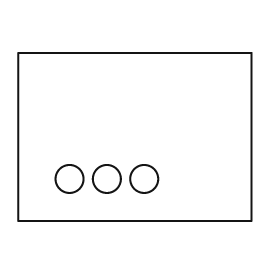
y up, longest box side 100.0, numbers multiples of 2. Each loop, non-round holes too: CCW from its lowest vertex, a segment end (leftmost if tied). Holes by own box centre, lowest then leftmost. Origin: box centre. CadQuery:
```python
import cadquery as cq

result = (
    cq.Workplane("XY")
    .moveTo(-50.0, -36.0)
    .lineTo(50.0, -36.0)
    .lineTo(50.0, 36.0)
    .lineTo(-50.0, 36.0)
    .close()
    .moveTo(-28.0, -18.0)
    .circle(6.0)
    .moveTo(-12.0, -18.0)
    .circle(6.0)
    .moveTo(4.0, -18.0)
    .circle(6.0)
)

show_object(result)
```